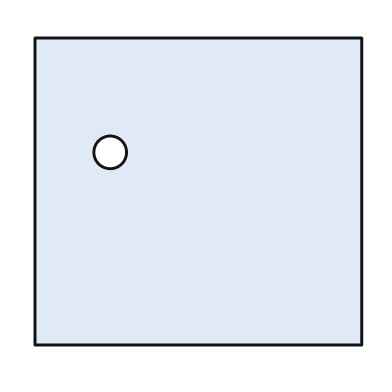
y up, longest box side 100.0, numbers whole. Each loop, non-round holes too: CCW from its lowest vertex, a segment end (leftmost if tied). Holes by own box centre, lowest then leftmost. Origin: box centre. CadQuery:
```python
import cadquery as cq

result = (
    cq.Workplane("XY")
    .moveTo(-50.0, -47.0)
    .lineTo(50.0, -47.0)
    .lineTo(50.0, 47.0)
    .lineTo(-50.0, 47.0)
    .close()
    .moveTo(-27.0, 12.0)
    .circle(5.0)
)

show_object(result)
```